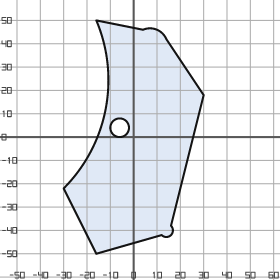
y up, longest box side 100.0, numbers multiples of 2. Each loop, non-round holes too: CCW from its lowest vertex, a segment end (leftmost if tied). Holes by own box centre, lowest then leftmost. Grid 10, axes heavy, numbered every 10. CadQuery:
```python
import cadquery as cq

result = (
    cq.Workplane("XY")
    .moveTo(-16.0, -50.0)
    .lineTo(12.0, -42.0)
    .threePointArc((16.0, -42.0), (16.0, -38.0))
    .lineTo(30.0, 18.0)
    .lineTo(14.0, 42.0)
    .threePointArc((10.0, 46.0), (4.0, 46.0))
    .lineTo(-16.0, 50.0)
    .threePointArc((-12.0, 12.0), (-30.0, -22.0))
    .close()
    .moveTo(-6.0, 4.0)
    .circle(4.0)
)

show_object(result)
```